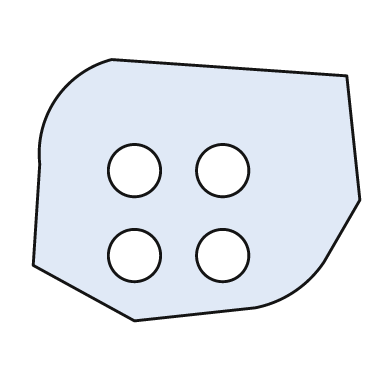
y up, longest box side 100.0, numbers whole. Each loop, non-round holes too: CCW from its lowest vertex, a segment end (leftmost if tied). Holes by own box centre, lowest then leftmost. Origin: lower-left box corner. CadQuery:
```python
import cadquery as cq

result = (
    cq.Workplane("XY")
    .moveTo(31.0, 0.0)
    .lineTo(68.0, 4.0)
    .threePointArc((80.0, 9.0), (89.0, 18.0))
    .lineTo(100.0, 37.0)
    .lineTo(96.0, 75.0)
    .lineTo(24.0, 80.0)
    .threePointArc((7.0, 68.0), (2.0, 48.0))
    .lineTo(0.0, 17.0)
    .close()
    .moveTo(31.0, 20.0)
    .circle(8.0)
    .moveTo(58.0, 20.0)
    .circle(8.0)
    .moveTo(31.0, 46.0)
    .circle(8.0)
    .moveTo(58.0, 46.0)
    .circle(8.0)
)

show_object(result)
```